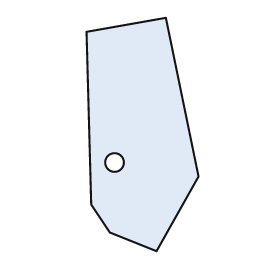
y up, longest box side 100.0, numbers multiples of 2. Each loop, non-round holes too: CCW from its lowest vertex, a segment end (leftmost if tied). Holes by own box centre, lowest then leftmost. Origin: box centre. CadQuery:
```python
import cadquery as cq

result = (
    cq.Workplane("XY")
    .moveTo(6.0, -50.0)
    .lineTo(24.0, -18.0)
    .lineTo(10.0, 50.0)
    .lineTo(-24.0, 44.0)
    .lineTo(-22.0, -30.0)
    .lineTo(-14.0, -42.0)
    .close()
    .moveTo(-12.0, -12.0)
    .circle(4.0)
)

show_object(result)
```